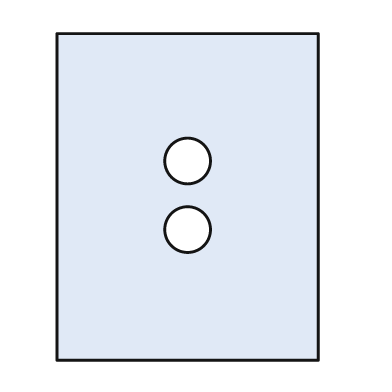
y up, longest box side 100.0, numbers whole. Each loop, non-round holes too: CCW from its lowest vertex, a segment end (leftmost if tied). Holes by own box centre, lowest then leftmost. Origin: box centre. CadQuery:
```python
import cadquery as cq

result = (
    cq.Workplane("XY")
    .moveTo(-40.0, -50.0)
    .lineTo(40.0, -50.0)
    .lineTo(40.0, 50.0)
    .lineTo(-40.0, 50.0)
    .close()
    .moveTo(0.0, -10.0)
    .circle(7.0)
    .moveTo(0.0, 11.0)
    .circle(7.0)
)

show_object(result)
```